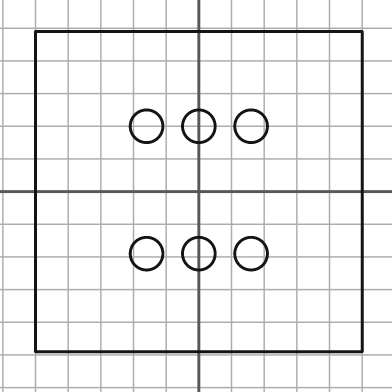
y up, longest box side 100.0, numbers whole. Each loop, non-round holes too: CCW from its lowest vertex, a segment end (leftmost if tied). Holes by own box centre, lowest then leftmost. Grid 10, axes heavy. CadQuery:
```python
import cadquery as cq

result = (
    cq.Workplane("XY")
    .moveTo(-50.0, -49.0)
    .lineTo(50.0, -49.0)
    .lineTo(50.0, 49.0)
    .lineTo(-50.0, 49.0)
    .close()
    .moveTo(-16.0, -19.0)
    .circle(5.0)
    .moveTo(0.0, -19.0)
    .circle(5.0)
    .moveTo(16.0, -19.0)
    .circle(5.0)
    .moveTo(-16.0, 20.0)
    .circle(5.0)
    .moveTo(0.0, 20.0)
    .circle(5.0)
    .moveTo(16.0, 20.0)
    .circle(5.0)
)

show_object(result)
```